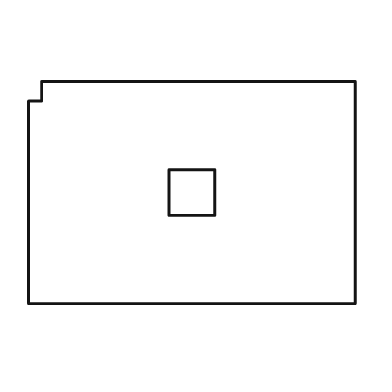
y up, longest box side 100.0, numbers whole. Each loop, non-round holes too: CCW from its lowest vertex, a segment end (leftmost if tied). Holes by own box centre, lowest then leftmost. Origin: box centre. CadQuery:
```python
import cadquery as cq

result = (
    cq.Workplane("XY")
    .moveTo(-50.0, -34.0)
    .lineTo(50.0, -34.0)
    .lineTo(50.0, 34.0)
    .lineTo(-46.0, 34.0)
    .lineTo(-46.0, 28.0)
    .lineTo(-50.0, 28.0)
    .close()
    .moveTo(-7.0, -7.0)
    .lineTo(7.0, -7.0)
    .lineTo(7.0, 7.0)
    .lineTo(-7.0, 7.0)
    .close()
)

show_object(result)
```